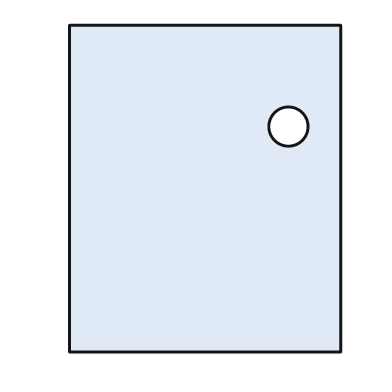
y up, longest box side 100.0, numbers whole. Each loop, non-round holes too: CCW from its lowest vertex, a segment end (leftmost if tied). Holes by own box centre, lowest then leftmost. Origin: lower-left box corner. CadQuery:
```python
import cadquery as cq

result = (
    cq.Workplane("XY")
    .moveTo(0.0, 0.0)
    .lineTo(83.0, 0.0)
    .lineTo(83.0, 100.0)
    .lineTo(0.0, 100.0)
    .close()
    .moveTo(67.0, 69.0)
    .circle(6.0)
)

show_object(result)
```